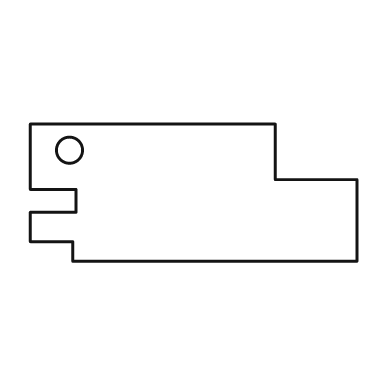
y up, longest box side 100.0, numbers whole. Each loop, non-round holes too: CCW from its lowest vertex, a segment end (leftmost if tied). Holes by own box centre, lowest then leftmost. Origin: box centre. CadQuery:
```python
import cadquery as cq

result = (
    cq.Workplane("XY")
    .moveTo(-37.0, -21.0)
    .lineTo(50.0, -21.0)
    .lineTo(50.0, 4.0)
    .lineTo(25.0, 4.0)
    .lineTo(25.0, 21.0)
    .lineTo(-50.0, 21.0)
    .lineTo(-50.0, 1.0)
    .lineTo(-36.0, 1.0)
    .lineTo(-36.0, -6.0)
    .lineTo(-50.0, -6.0)
    .lineTo(-50.0, -15.0)
    .lineTo(-37.0, -15.0)
    .close()
    .moveTo(-38.0, 13.0)
    .circle(4.0)
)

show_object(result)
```